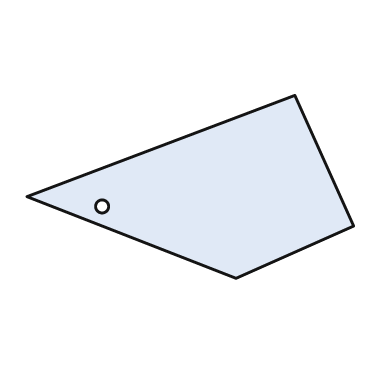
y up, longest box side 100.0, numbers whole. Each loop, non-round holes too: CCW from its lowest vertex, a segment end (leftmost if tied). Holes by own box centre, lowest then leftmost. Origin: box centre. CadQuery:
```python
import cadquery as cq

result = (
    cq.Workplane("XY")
    .moveTo(14.0, -28.0)
    .lineTo(50.0, -12.0)
    .lineTo(32.0, 28.0)
    .lineTo(-50.0, -3.0)
    .close()
    .moveTo(-27.0, -6.0)
    .circle(2.0)
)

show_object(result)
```